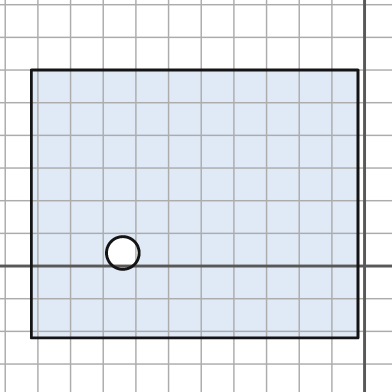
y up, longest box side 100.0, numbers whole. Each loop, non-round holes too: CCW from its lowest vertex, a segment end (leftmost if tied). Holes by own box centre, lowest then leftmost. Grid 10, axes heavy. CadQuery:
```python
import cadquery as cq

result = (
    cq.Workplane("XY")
    .moveTo(-102.0, -22.0)
    .lineTo(-2.0, -22.0)
    .lineTo(-2.0, 60.0)
    .lineTo(-102.0, 60.0)
    .close()
    .moveTo(-74.0, 4.0)
    .circle(5.0)
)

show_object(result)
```